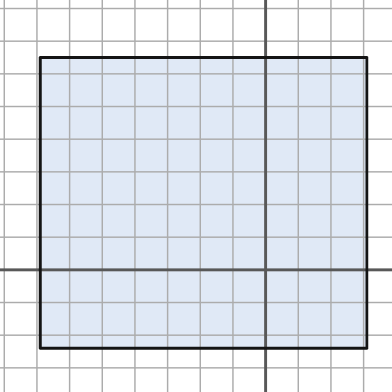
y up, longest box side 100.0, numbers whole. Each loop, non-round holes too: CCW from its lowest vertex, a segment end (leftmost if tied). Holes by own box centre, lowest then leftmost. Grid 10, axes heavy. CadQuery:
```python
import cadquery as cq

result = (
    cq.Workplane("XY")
    .moveTo(-69.0, -24.0)
    .lineTo(31.0, -24.0)
    .lineTo(31.0, 65.0)
    .lineTo(-69.0, 65.0)
    .close()
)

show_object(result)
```